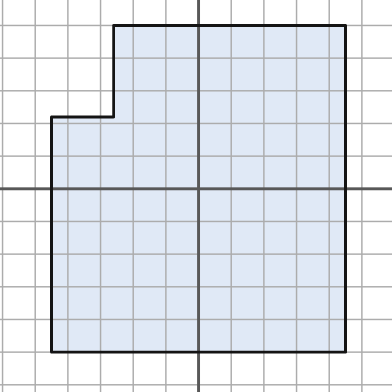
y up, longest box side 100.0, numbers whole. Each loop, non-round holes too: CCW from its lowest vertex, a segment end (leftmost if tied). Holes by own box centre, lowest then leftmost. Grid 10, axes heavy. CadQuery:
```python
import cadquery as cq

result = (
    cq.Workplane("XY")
    .moveTo(-45.0, -50.0)
    .lineTo(45.0, -50.0)
    .lineTo(45.0, 50.0)
    .lineTo(-26.0, 50.0)
    .lineTo(-26.0, 22.0)
    .lineTo(-45.0, 22.0)
    .close()
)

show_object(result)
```